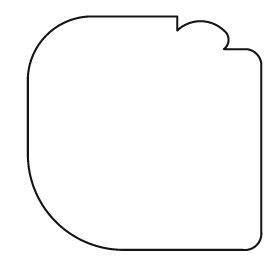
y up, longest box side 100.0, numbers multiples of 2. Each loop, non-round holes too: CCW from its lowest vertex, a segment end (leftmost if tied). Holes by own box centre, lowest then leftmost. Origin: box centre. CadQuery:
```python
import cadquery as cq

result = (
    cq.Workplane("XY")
    .moveTo(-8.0, -50.0)
    .lineTo(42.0, -50.0)
    .threePointArc((48.0, -48.0), (50.0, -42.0))
    .lineTo(50.0, 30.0)
    .threePointArc((48.0, 34.0), (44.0, 36.0))
    .lineTo(34.0, 36.0)
    .threePointArc((36.0, 40.0), (34.0, 44.0))
    .threePointArc((24.0, 48.0), (14.0, 44.0))
    .lineTo(14.0, 50.0)
    .lineTo(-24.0, 50.0)
    .threePointArc((-42.0, 42.0), (-50.0, 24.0))
    .lineTo(-50.0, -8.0)
    .threePointArc((-38.0, -38.0), (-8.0, -50.0))
    .close()
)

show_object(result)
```